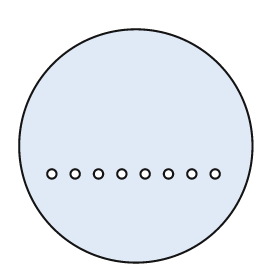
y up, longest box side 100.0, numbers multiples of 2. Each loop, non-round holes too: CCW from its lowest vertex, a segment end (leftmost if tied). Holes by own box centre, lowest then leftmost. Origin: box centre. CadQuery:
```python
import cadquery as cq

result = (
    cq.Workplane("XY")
    .moveTo(0.0, 0.0)
    .circle(50.0)
    .moveTo(-36.0, -12.0)
    .circle(2.0)
    .moveTo(-26.0, -12.0)
    .circle(2.0)
    .moveTo(-16.0, -12.0)
    .circle(2.0)
    .moveTo(-6.0, -12.0)
    .circle(2.0)
    .moveTo(4.0, -12.0)
    .circle(2.0)
    .moveTo(14.0, -12.0)
    .circle(2.0)
    .moveTo(24.0, -12.0)
    .circle(2.0)
    .moveTo(34.0, -12.0)
    .circle(2.0)
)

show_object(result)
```